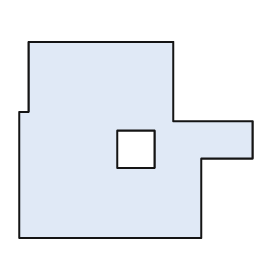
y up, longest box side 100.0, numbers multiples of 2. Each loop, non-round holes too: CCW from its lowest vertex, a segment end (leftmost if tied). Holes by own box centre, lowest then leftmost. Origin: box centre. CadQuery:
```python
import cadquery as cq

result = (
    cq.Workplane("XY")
    .moveTo(-50.0, -42.0)
    .lineTo(28.0, -42.0)
    .lineTo(28.0, -8.0)
    .lineTo(50.0, -8.0)
    .lineTo(50.0, 8.0)
    .lineTo(16.0, 8.0)
    .lineTo(16.0, 42.0)
    .lineTo(-46.0, 42.0)
    .lineTo(-46.0, 12.0)
    .lineTo(-50.0, 12.0)
    .close()
    .moveTo(-8.0, -12.0)
    .lineTo(8.0, -12.0)
    .lineTo(8.0, 4.0)
    .lineTo(-8.0, 4.0)
    .close()
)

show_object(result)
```